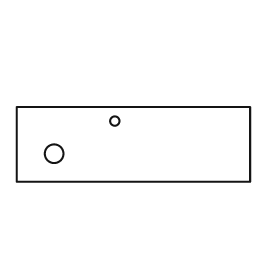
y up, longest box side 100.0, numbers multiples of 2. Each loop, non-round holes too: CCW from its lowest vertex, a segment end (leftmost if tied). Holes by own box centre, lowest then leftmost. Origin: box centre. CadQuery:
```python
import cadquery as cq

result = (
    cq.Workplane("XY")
    .moveTo(-50.0, -16.0)
    .lineTo(50.0, -16.0)
    .lineTo(50.0, 16.0)
    .lineTo(-50.0, 16.0)
    .close()
    .moveTo(-34.0, -4.0)
    .circle(4.0)
    .moveTo(-8.0, 10.0)
    .circle(2.0)
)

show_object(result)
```